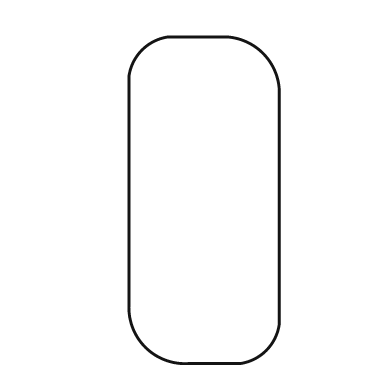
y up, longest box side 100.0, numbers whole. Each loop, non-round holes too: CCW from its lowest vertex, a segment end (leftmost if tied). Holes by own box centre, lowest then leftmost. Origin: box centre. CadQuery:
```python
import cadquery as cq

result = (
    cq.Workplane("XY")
    .moveTo(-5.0, -50.0)
    .lineTo(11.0, -50.0)
    .threePointArc((19.0, -46.0), (23.0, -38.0))
    .lineTo(23.0, 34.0)
    .threePointArc((18.0, 45.0), (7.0, 50.0))
    .lineTo(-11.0, 50.0)
    .threePointArc((-19.0, 46.0), (-23.0, 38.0))
    .lineTo(-23.0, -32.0)
    .threePointArc((-18.0, -45.0), (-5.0, -50.0))
    .close()
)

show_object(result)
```